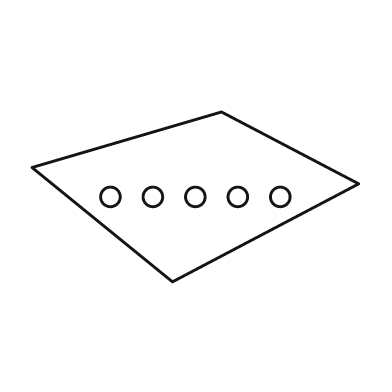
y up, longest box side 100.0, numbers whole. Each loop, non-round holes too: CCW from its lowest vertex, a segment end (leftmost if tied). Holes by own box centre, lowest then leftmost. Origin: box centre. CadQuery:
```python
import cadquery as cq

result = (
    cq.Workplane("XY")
    .moveTo(-7.0, -26.0)
    .lineTo(50.0, 4.0)
    .lineTo(8.0, 26.0)
    .lineTo(-50.0, 9.0)
    .close()
    .moveTo(-26.0, 0.0)
    .circle(3.0)
    .moveTo(-13.0, 0.0)
    .circle(3.0)
    .moveTo(0.0, 0.0)
    .circle(3.0)
    .moveTo(13.0, 0.0)
    .circle(3.0)
    .moveTo(26.0, 0.0)
    .circle(3.0)
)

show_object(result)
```